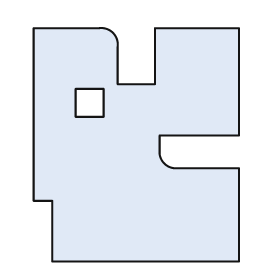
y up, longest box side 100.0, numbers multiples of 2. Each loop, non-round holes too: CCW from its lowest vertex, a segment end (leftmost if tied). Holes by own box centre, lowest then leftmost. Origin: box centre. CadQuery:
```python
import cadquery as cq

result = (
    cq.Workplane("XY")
    .moveTo(-36.0, -50.0)
    .lineTo(44.0, -50.0)
    .lineTo(44.0, -10.0)
    .lineTo(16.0, -10.0)
    .threePointArc((12.0, -8.0), (10.0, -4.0))
    .lineTo(10.0, 4.0)
    .lineTo(44.0, 4.0)
    .lineTo(44.0, 50.0)
    .lineTo(8.0, 50.0)
    .lineTo(8.0, 26.0)
    .lineTo(-8.0, 26.0)
    .lineTo(-8.0, 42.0)
    .threePointArc((-10.0, 48.0), (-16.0, 50.0))
    .lineTo(-44.0, 50.0)
    .lineTo(-44.0, -24.0)
    .lineTo(-36.0, -24.0)
    .close()
    .moveTo(-26.0, 12.0)
    .lineTo(-14.0, 12.0)
    .lineTo(-14.0, 24.0)
    .lineTo(-26.0, 24.0)
    .close()
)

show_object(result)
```